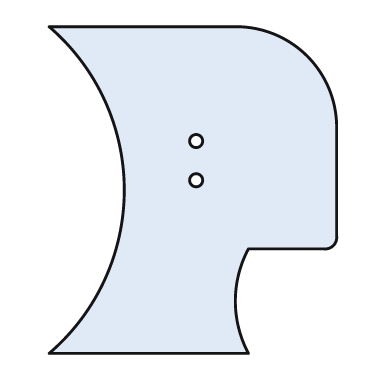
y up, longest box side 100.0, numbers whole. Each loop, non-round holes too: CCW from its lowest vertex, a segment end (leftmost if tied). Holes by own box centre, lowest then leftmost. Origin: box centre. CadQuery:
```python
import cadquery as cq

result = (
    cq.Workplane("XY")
    .moveTo(-44.0, -50.0)
    .lineTo(17.0, -50.0)
    .threePointArc((13.0, -34.0), (17.0, -18.0))
    .lineTo(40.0, -18.0)
    .threePointArc((43.0, -17.0), (44.0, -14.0))
    .lineTo(44.0, 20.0)
    .threePointArc((35.0, 41.0), (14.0, 50.0))
    .lineTo(-44.0, 50.0)
    .threePointArc((-21.0, 0.0), (-44.0, -50.0))
    .close()
    .moveTo(1.0, 3.0)
    .circle(2.0)
    .moveTo(1.0, 15.0)
    .circle(2.0)
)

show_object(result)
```